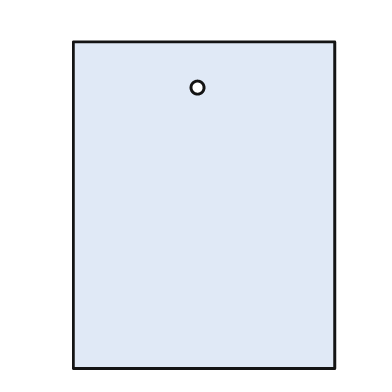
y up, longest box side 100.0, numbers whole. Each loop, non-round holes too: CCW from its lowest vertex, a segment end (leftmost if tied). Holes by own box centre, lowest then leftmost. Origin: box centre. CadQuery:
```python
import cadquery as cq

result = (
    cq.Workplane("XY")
    .moveTo(-40.0, -50.0)
    .lineTo(40.0, -50.0)
    .lineTo(40.0, 50.0)
    .lineTo(-40.0, 50.0)
    .close()
    .moveTo(-2.0, 36.0)
    .circle(2.0)
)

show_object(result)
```